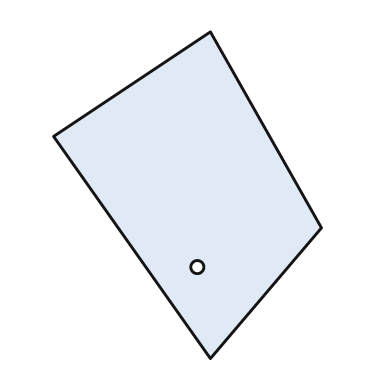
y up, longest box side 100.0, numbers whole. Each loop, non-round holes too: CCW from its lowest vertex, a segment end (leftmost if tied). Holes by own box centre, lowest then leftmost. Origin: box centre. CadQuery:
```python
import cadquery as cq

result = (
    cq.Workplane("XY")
    .moveTo(7.0, -50.0)
    .lineTo(41.0, -10.0)
    .lineTo(7.0, 50.0)
    .lineTo(-41.0, 18.0)
    .close()
    .moveTo(3.0, -22.0)
    .circle(2.0)
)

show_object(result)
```